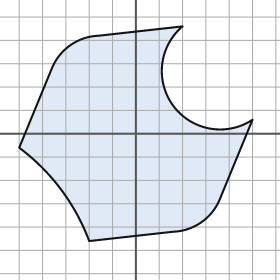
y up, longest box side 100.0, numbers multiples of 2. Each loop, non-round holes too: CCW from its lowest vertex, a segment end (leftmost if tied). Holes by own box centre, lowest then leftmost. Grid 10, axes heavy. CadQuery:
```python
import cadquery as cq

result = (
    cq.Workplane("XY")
    .moveTo(-20.0, -46.0)
    .lineTo(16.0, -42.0)
    .threePointArc((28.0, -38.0), (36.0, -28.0))
    .lineTo(50.0, 6.0)
    .threePointArc((16.0, 12.0), (20.0, 46.0))
    .lineTo(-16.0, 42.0)
    .threePointArc((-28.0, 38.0), (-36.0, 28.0))
    .lineTo(-50.0, -6.0)
    .threePointArc((-32.0, -24.0), (-20.0, -46.0))
    .close()
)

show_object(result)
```